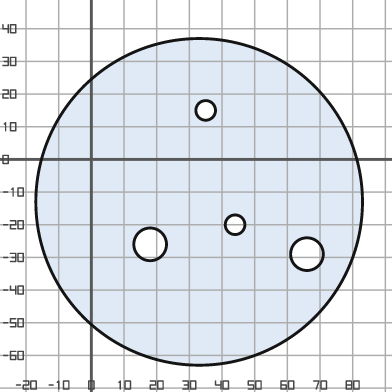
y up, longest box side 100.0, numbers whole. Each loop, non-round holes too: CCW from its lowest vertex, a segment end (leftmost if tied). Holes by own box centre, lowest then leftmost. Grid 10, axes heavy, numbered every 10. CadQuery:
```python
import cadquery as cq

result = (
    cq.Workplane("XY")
    .moveTo(33.0, -13.0)
    .circle(50.0)
    .moveTo(66.0, -29.0)
    .circle(5.0)
    .moveTo(18.0, -26.0)
    .circle(5.0)
    .moveTo(44.0, -20.0)
    .circle(3.0)
    .moveTo(35.0, 15.0)
    .circle(3.0)
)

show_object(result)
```